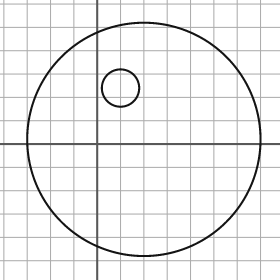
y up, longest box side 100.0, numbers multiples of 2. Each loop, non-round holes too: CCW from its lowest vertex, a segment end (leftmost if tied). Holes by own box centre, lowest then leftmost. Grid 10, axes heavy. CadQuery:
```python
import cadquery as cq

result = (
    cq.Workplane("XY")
    .moveTo(20.0, 2.0)
    .circle(50.0)
    .moveTo(10.0, 24.0)
    .circle(8.0)
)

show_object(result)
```